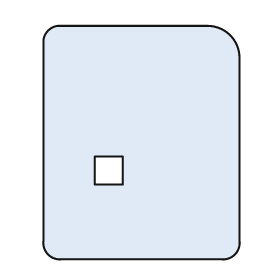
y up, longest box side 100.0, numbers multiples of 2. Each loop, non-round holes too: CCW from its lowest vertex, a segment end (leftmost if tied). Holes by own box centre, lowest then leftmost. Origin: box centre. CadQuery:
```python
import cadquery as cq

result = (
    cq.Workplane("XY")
    .moveTo(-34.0, -50.0)
    .lineTo(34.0, -50.0)
    .threePointArc((40.0, -48.0), (42.0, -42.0))
    .lineTo(42.0, 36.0)
    .threePointArc((38.0, 46.0), (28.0, 50.0))
    .lineTo(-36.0, 50.0)
    .threePointArc((-40.0, 48.0), (-42.0, 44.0))
    .lineTo(-42.0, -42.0)
    .threePointArc((-40.0, -48.0), (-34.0, -50.0))
    .close()
    .moveTo(-20.0, -18.0)
    .lineTo(-8.0, -18.0)
    .lineTo(-8.0, -6.0)
    .lineTo(-20.0, -6.0)
    .close()
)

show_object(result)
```